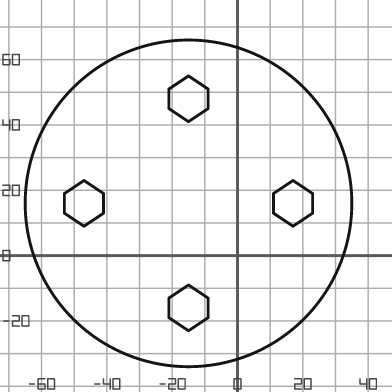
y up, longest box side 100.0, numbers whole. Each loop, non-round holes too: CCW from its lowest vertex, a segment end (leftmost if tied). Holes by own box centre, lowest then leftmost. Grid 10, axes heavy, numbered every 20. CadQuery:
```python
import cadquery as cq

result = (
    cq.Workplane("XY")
    .moveTo(-15.0, 16.0)
    .circle(50.0)
    .moveTo(-15.0, -23.0)
    .lineTo(-9.0, -19.0)
    .lineTo(-9.0, -13.0)
    .lineTo(-15.0, -9.0)
    .lineTo(-21.0, -13.0)
    .lineTo(-21.0, -19.0)
    .close()
    .moveTo(-47.0, 9.0)
    .lineTo(-41.0, 13.0)
    .lineTo(-41.0, 19.0)
    .lineTo(-47.0, 23.0)
    .lineTo(-53.0, 19.0)
    .lineTo(-53.0, 13.0)
    .close()
    .moveTo(17.0, 9.0)
    .lineTo(23.0, 13.0)
    .lineTo(23.0, 19.0)
    .lineTo(17.0, 23.0)
    .lineTo(11.0, 19.0)
    .lineTo(11.0, 13.0)
    .close()
    .moveTo(-15.0, 41.0)
    .lineTo(-9.0, 45.0)
    .lineTo(-9.0, 51.0)
    .lineTo(-15.0, 55.0)
    .lineTo(-21.0, 51.0)
    .lineTo(-21.0, 45.0)
    .close()
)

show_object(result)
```